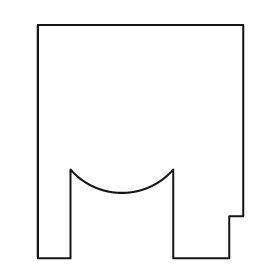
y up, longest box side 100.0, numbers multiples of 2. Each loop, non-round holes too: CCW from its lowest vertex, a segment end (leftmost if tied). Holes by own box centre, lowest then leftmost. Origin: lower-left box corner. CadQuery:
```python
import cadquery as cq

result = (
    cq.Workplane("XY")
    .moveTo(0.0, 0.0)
    .lineTo(14.0, 0.0)
    .lineTo(14.0, 38.0)
    .threePointArc((36.0, 28.0), (58.0, 38.0))
    .lineTo(58.0, 0.0)
    .lineTo(82.0, 0.0)
    .lineTo(82.0, 18.0)
    .lineTo(88.0, 18.0)
    .lineTo(88.0, 100.0)
    .lineTo(0.0, 100.0)
    .close()
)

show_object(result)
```